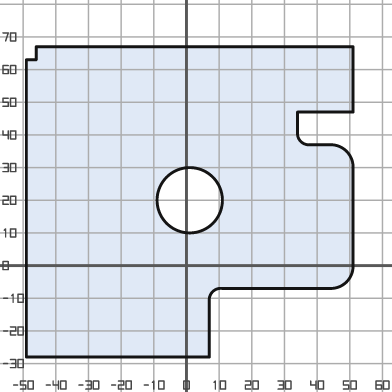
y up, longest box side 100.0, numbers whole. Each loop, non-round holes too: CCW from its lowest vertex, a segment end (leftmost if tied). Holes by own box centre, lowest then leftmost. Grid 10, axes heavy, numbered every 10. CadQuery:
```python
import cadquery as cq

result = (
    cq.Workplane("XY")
    .moveTo(-49.0, -28.0)
    .lineTo(7.0, -28.0)
    .lineTo(7.0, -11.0)
    .threePointArc((8.0, -8.0), (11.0, -7.0))
    .lineTo(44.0, -7.0)
    .threePointArc((49.0, -5.0), (51.0, 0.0))
    .lineTo(51.0, 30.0)
    .threePointArc((49.0, 35.0), (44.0, 37.0))
    .lineTo(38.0, 37.0)
    .threePointArc((35.0, 38.0), (34.0, 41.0))
    .lineTo(34.0, 47.0)
    .lineTo(51.0, 47.0)
    .lineTo(51.0, 67.0)
    .lineTo(-46.0, 67.0)
    .lineTo(-46.0, 63.0)
    .lineTo(-49.0, 63.0)
    .close()
    .moveTo(1.0, 20.0)
    .circle(10.0)
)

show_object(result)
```